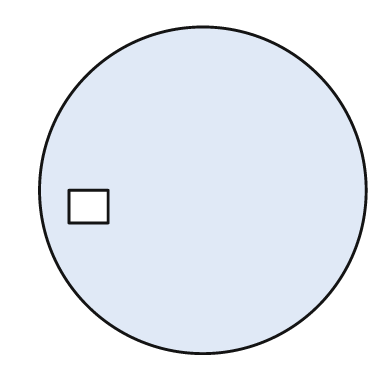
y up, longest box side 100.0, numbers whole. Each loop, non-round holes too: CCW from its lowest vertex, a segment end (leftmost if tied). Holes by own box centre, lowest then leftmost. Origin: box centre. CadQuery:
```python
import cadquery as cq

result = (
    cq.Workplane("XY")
    .moveTo(0.0, 0.0)
    .circle(50.0)
    .moveTo(-41.0, -10.0)
    .lineTo(-29.0, -10.0)
    .lineTo(-29.0, 0.0)
    .lineTo(-41.0, 0.0)
    .close()
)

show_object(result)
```